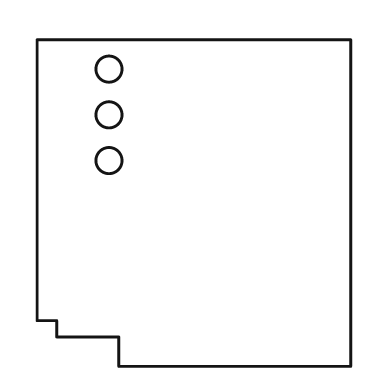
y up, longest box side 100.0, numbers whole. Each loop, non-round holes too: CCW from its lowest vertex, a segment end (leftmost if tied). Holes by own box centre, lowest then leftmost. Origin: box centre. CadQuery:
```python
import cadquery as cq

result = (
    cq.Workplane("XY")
    .moveTo(-23.0, -50.0)
    .lineTo(48.0, -50.0)
    .lineTo(48.0, 50.0)
    .lineTo(-48.0, 50.0)
    .lineTo(-48.0, -36.0)
    .lineTo(-42.0, -36.0)
    .lineTo(-42.0, -41.0)
    .lineTo(-23.0, -41.0)
    .close()
    .moveTo(-26.0, 13.0)
    .circle(4.0)
    .moveTo(-26.0, 27.0)
    .circle(4.0)
    .moveTo(-26.0, 41.0)
    .circle(4.0)
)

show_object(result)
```